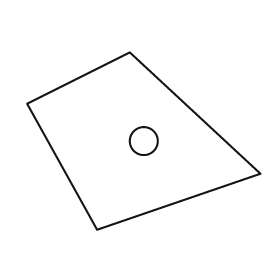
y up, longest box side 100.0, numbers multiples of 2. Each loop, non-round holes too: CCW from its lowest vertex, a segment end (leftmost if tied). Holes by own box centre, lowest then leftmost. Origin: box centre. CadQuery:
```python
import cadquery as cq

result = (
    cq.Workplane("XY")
    .moveTo(-20.0, -38.0)
    .lineTo(50.0, -14.0)
    .lineTo(-6.0, 38.0)
    .lineTo(-50.0, 16.0)
    .close()
    .moveTo(0.0, 0.0)
    .circle(6.0)
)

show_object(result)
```